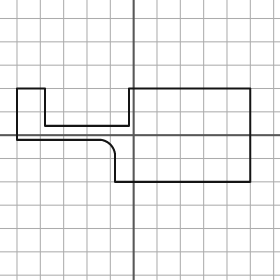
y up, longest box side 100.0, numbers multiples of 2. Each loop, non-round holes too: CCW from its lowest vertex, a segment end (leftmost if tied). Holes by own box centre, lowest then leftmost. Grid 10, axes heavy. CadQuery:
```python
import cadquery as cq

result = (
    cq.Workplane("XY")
    .moveTo(-8.0, -20.0)
    .lineTo(50.0, -20.0)
    .lineTo(50.0, 20.0)
    .lineTo(-2.0, 20.0)
    .lineTo(-2.0, 4.0)
    .lineTo(-38.0, 4.0)
    .lineTo(-38.0, 20.0)
    .lineTo(-50.0, 20.0)
    .lineTo(-50.0, -2.0)
    .lineTo(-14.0, -2.0)
    .threePointArc((-10.0, -4.0), (-8.0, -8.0))
    .close()
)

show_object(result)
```